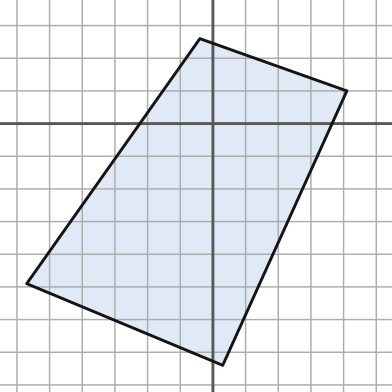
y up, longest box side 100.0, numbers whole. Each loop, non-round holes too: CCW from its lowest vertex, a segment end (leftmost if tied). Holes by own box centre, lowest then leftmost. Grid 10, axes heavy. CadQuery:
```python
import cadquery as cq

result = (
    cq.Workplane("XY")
    .moveTo(3.0, -74.0)
    .lineTo(41.0, 10.0)
    .lineTo(-4.0, 26.0)
    .lineTo(-57.0, -49.0)
    .close()
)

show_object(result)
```